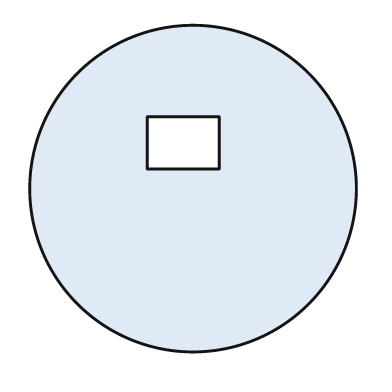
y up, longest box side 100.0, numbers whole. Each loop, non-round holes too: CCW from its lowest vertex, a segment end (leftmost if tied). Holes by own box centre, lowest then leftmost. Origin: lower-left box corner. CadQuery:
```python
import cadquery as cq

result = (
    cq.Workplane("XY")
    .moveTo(50.0, 50.0)
    .circle(50.0)
    .moveTo(36.0, 56.0)
    .lineTo(58.0, 56.0)
    .lineTo(58.0, 72.0)
    .lineTo(36.0, 72.0)
    .close()
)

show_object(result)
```